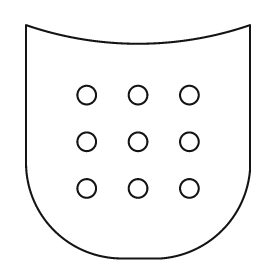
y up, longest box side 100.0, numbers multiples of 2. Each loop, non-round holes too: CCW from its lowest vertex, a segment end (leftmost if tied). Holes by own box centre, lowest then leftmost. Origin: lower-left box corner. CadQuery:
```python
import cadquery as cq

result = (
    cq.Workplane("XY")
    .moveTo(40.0, 0.0)
    .lineTo(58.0, 0.0)
    .threePointArc((84.0, 12.0), (96.0, 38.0))
    .lineTo(96.0, 100.0)
    .threePointArc((48.0, 92.0), (0.0, 100.0))
    .lineTo(0.0, 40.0)
    .threePointArc((12.0, 12.0), (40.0, 0.0))
    .close()
    .moveTo(26.0, 30.0)
    .circle(4.0)
    .moveTo(48.0, 30.0)
    .circle(4.0)
    .moveTo(70.0, 30.0)
    .circle(4.0)
    .moveTo(26.0, 50.0)
    .circle(4.0)
    .moveTo(48.0, 50.0)
    .circle(4.0)
    .moveTo(70.0, 50.0)
    .circle(4.0)
    .moveTo(26.0, 70.0)
    .circle(4.0)
    .moveTo(48.0, 70.0)
    .circle(4.0)
    .moveTo(70.0, 70.0)
    .circle(4.0)
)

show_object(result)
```